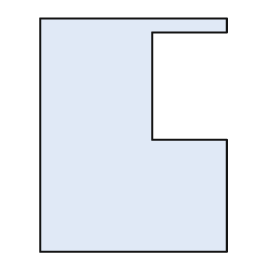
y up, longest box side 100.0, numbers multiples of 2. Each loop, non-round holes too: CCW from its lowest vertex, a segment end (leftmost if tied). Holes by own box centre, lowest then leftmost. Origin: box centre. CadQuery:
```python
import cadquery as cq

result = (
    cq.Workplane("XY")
    .moveTo(-40.0, -50.0)
    .lineTo(40.0, -50.0)
    .lineTo(40.0, -2.0)
    .lineTo(8.0, -2.0)
    .lineTo(8.0, 44.0)
    .lineTo(40.0, 44.0)
    .lineTo(40.0, 50.0)
    .lineTo(-40.0, 50.0)
    .close()
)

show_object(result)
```